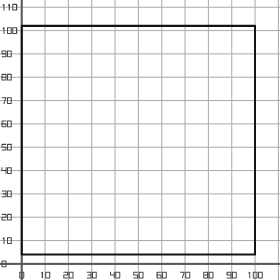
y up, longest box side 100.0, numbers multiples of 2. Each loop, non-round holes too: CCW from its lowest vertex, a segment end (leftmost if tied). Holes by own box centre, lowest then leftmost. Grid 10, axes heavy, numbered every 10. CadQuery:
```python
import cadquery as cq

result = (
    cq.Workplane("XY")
    .moveTo(0.0, 4.0)
    .lineTo(100.0, 4.0)
    .lineTo(100.0, 102.0)
    .lineTo(0.0, 102.0)
    .close()
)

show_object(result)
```